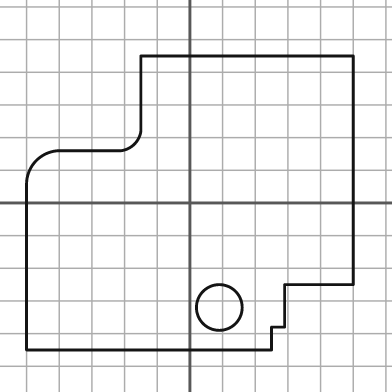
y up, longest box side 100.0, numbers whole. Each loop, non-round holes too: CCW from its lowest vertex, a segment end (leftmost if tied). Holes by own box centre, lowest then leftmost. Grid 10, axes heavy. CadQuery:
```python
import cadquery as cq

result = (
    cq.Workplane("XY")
    .moveTo(-50.0, -45.0)
    .lineTo(25.0, -45.0)
    .lineTo(25.0, -38.0)
    .lineTo(29.0, -38.0)
    .lineTo(29.0, -25.0)
    .lineTo(50.0, -25.0)
    .lineTo(50.0, 45.0)
    .lineTo(-15.0, 45.0)
    .lineTo(-15.0, 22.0)
    .threePointArc((-17.0, 18.0), (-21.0, 16.0))
    .lineTo(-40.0, 16.0)
    .threePointArc((-47.0, 13.0), (-50.0, 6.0))
    .close()
    .moveTo(9.0, -32.0)
    .circle(7.0)
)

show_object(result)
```